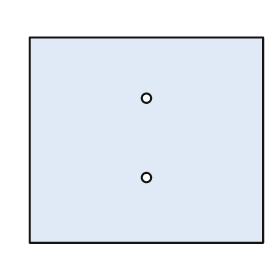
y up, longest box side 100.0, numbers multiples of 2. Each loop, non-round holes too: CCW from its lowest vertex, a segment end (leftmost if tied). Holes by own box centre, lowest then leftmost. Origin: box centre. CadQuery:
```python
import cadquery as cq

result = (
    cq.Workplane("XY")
    .moveTo(-50.0, -44.0)
    .lineTo(50.0, -44.0)
    .lineTo(50.0, 44.0)
    .lineTo(-50.0, 44.0)
    .close()
    .moveTo(0.0, -16.0)
    .circle(2.0)
    .moveTo(0.0, 18.0)
    .circle(2.0)
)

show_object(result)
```